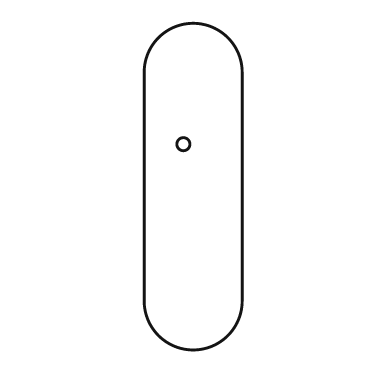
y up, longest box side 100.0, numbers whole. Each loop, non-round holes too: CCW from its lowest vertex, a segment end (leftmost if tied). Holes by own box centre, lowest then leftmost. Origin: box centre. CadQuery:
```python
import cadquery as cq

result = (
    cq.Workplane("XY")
    .moveTo(-15.0, -35.0)
    .threePointArc((0.0, -50.0), (15.0, -35.0))
    .lineTo(15.0, 35.0)
    .threePointArc((0.0, 50.0), (-15.0, 35.0))
    .close()
    .moveTo(-3.0, 13.0)
    .circle(2.0)
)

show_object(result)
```